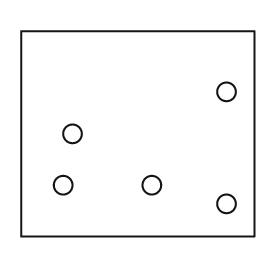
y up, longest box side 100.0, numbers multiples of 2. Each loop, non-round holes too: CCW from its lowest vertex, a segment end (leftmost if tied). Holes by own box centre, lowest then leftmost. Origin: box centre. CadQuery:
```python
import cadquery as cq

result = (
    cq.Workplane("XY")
    .moveTo(-50.0, -44.0)
    .lineTo(50.0, -44.0)
    .lineTo(50.0, 44.0)
    .lineTo(-50.0, 44.0)
    .close()
    .moveTo(38.0, -30.0)
    .circle(4.0)
    .moveTo(-32.0, -22.0)
    .circle(4.0)
    .moveTo(6.0, -22.0)
    .circle(4.0)
    .moveTo(-28.0, 0.0)
    .circle(4.0)
    .moveTo(38.0, 18.0)
    .circle(4.0)
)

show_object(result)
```